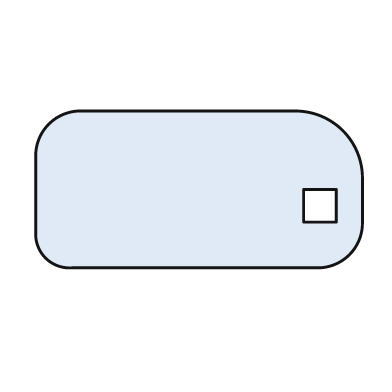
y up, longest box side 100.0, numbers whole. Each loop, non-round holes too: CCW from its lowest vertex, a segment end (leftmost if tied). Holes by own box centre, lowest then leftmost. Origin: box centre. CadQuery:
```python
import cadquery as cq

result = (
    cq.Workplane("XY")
    .moveTo(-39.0, -24.0)
    .lineTo(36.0, -24.0)
    .threePointArc((46.0, -20.0), (50.0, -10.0))
    .lineTo(50.0, 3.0)
    .threePointArc((44.0, 18.0), (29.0, 24.0))
    .lineTo(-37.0, 24.0)
    .threePointArc((-46.0, 20.0), (-50.0, 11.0))
    .lineTo(-50.0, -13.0)
    .threePointArc((-47.0, -21.0), (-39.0, -24.0))
    .close()
    .moveTo(32.0, -10.0)
    .lineTo(42.0, -10.0)
    .lineTo(42.0, 0.0)
    .lineTo(32.0, 0.0)
    .close()
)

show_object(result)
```